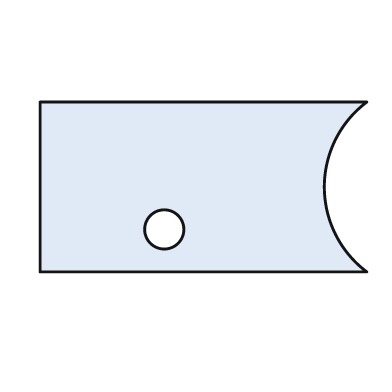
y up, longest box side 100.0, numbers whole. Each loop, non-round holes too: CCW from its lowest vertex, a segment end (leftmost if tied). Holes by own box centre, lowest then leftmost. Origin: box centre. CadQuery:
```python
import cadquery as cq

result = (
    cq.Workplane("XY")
    .moveTo(-50.0, -26.0)
    .lineTo(50.0, -26.0)
    .threePointArc((37.0, 0.0), (50.0, 26.0))
    .lineTo(-50.0, 26.0)
    .close()
    .moveTo(-12.0, -13.0)
    .circle(6.0)
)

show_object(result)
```